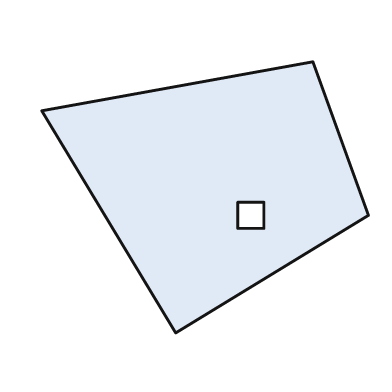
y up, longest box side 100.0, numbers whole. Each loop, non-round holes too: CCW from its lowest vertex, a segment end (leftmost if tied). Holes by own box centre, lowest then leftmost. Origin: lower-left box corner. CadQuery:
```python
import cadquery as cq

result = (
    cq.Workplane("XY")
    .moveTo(41.0, 0.0)
    .lineTo(100.0, 36.0)
    .lineTo(83.0, 83.0)
    .lineTo(0.0, 68.0)
    .close()
    .moveTo(60.0, 32.0)
    .lineTo(68.0, 32.0)
    .lineTo(68.0, 40.0)
    .lineTo(60.0, 40.0)
    .close()
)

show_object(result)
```